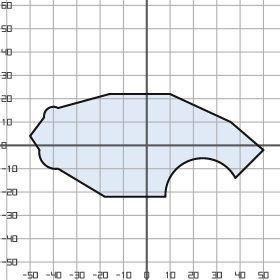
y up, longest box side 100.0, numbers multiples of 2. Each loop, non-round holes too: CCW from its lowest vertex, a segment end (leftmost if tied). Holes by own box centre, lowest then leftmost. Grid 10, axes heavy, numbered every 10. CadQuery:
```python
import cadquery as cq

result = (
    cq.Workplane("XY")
    .moveTo(-18.0, -22.0)
    .lineTo(8.0, -22.0)
    .threePointArc((20.0, -6.0), (38.0, -14.0))
    .lineTo(50.0, -2.0)
    .lineTo(36.0, 10.0)
    .lineTo(10.0, 22.0)
    .lineTo(-16.0, 22.0)
    .lineTo(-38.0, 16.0)
    .threePointArc((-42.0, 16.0), (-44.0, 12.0))
    .lineTo(-50.0, 4.0)
    .lineTo(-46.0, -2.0)
    .threePointArc((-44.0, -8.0), (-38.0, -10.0))
    .close()
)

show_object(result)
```